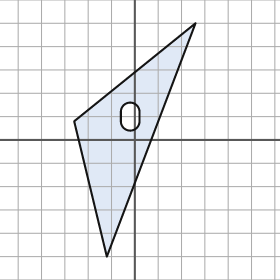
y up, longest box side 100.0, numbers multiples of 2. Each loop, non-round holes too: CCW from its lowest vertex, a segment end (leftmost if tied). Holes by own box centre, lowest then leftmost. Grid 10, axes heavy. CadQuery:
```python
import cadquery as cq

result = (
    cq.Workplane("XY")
    .moveTo(-12.0, -50.0)
    .lineTo(26.0, 50.0)
    .lineTo(-26.0, 8.0)
    .close()
    .moveTo(-6.0, 8.0)
    .threePointArc((-2.0, 4.0), (2.0, 8.0))
    .lineTo(2.0, 12.0)
    .threePointArc((-2.0, 16.0), (-6.0, 12.0))
    .close()
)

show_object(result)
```